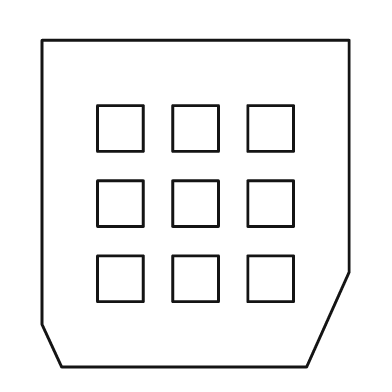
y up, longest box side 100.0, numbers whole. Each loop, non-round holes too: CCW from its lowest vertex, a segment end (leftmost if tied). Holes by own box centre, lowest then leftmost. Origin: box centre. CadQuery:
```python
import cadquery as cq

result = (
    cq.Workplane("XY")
    .moveTo(-41.0, -50.0)
    .lineTo(34.0, -50.0)
    .lineTo(47.0, -21.0)
    .lineTo(47.0, 50.0)
    .lineTo(-47.0, 50.0)
    .lineTo(-47.0, -37.0)
    .close()
    .moveTo(-30.0, -30.0)
    .lineTo(-16.0, -30.0)
    .lineTo(-16.0, -16.0)
    .lineTo(-30.0, -16.0)
    .close()
    .moveTo(-7.0, -30.0)
    .lineTo(7.0, -30.0)
    .lineTo(7.0, -16.0)
    .lineTo(-7.0, -16.0)
    .close()
    .moveTo(16.0, -30.0)
    .lineTo(30.0, -30.0)
    .lineTo(30.0, -16.0)
    .lineTo(16.0, -16.0)
    .close()
    .moveTo(-30.0, -7.0)
    .lineTo(-16.0, -7.0)
    .lineTo(-16.0, 7.0)
    .lineTo(-30.0, 7.0)
    .close()
    .moveTo(-7.0, -7.0)
    .lineTo(7.0, -7.0)
    .lineTo(7.0, 7.0)
    .lineTo(-7.0, 7.0)
    .close()
    .moveTo(16.0, -7.0)
    .lineTo(30.0, -7.0)
    .lineTo(30.0, 7.0)
    .lineTo(16.0, 7.0)
    .close()
    .moveTo(-30.0, 16.0)
    .lineTo(-16.0, 16.0)
    .lineTo(-16.0, 30.0)
    .lineTo(-30.0, 30.0)
    .close()
    .moveTo(-7.0, 16.0)
    .lineTo(7.0, 16.0)
    .lineTo(7.0, 30.0)
    .lineTo(-7.0, 30.0)
    .close()
    .moveTo(16.0, 16.0)
    .lineTo(30.0, 16.0)
    .lineTo(30.0, 30.0)
    .lineTo(16.0, 30.0)
    .close()
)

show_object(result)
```